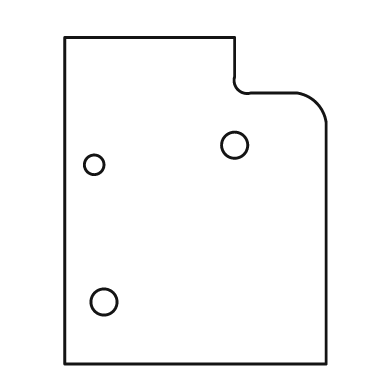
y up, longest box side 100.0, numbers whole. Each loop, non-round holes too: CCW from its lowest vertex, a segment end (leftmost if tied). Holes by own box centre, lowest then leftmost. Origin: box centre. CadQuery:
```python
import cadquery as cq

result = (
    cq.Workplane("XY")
    .moveTo(-40.0, -50.0)
    .lineTo(40.0, -50.0)
    .lineTo(40.0, 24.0)
    .threePointArc((37.0, 30.0), (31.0, 33.0))
    .lineTo(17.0, 33.0)
    .threePointArc((13.0, 34.0), (12.0, 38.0))
    .lineTo(12.0, 50.0)
    .lineTo(-40.0, 50.0)
    .close()
    .moveTo(-28.0, -31.0)
    .circle(4.0)
    .moveTo(-31.0, 11.0)
    .circle(3.0)
    .moveTo(12.0, 17.0)
    .circle(4.0)
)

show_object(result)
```